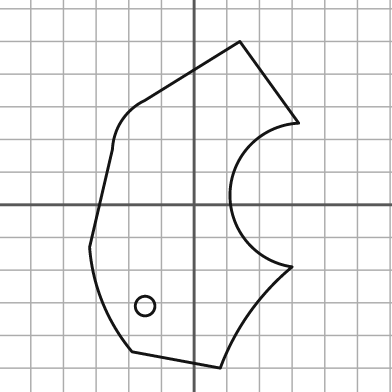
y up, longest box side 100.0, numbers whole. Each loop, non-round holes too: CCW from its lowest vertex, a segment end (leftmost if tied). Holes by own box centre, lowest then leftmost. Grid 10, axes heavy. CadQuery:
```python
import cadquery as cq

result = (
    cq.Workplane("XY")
    .moveTo(8.0, -50.0)
    .threePointArc((17.0, -33.0), (30.0, -19.0))
    .threePointArc((11.0, 4.0), (32.0, 25.0))
    .lineTo(14.0, 50.0)
    .lineTo(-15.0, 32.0)
    .threePointArc((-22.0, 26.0), (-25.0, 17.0))
    .lineTo(-32.0, -13.0)
    .threePointArc((-28.0, -30.0), (-19.0, -45.0))
    .close()
    .moveTo(-15.0, -31.0)
    .circle(3.0)
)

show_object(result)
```